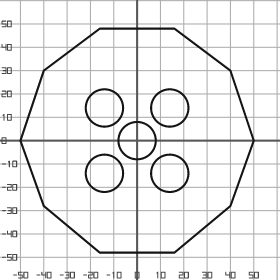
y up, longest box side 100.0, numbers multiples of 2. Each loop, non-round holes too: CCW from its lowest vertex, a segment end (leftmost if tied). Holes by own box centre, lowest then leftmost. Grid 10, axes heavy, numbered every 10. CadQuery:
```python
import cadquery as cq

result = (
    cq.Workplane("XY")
    .moveTo(-16.0, -48.0)
    .lineTo(16.0, -48.0)
    .lineTo(40.0, -28.0)
    .lineTo(50.0, 0.0)
    .lineTo(40.0, 30.0)
    .lineTo(16.0, 48.0)
    .lineTo(-16.0, 48.0)
    .lineTo(-40.0, 30.0)
    .lineTo(-50.0, 0.0)
    .lineTo(-40.0, -28.0)
    .close()
    .moveTo(-14.0, -14.0)
    .circle(8.0)
    .moveTo(14.0, -14.0)
    .circle(8.0)
    .moveTo(0.0, 0.0)
    .circle(8.0)
    .moveTo(-14.0, 14.0)
    .circle(8.0)
    .moveTo(14.0, 14.0)
    .circle(8.0)
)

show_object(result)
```